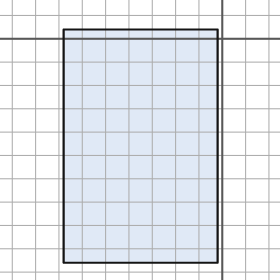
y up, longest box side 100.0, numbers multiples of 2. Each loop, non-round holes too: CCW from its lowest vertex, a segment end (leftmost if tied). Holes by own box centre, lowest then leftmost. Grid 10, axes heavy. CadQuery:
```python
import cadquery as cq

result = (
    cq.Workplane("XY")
    .moveTo(-68.0, -96.0)
    .lineTo(-2.0, -96.0)
    .lineTo(-2.0, 4.0)
    .lineTo(-68.0, 4.0)
    .close()
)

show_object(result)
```